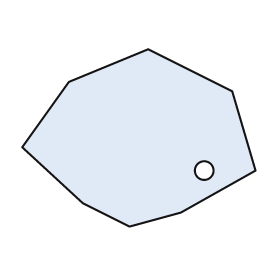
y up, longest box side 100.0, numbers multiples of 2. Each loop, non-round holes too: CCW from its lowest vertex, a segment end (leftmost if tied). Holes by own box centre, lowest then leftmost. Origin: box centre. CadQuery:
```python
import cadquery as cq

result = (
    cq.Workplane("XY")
    .moveTo(-4.0, -38.0)
    .lineTo(18.0, -32.0)
    .lineTo(50.0, -14.0)
    .lineTo(40.0, 20.0)
    .lineTo(4.0, 38.0)
    .lineTo(-30.0, 24.0)
    .lineTo(-50.0, -4.0)
    .lineTo(-24.0, -28.0)
    .close()
    .moveTo(28.0, -14.0)
    .circle(4.0)
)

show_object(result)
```